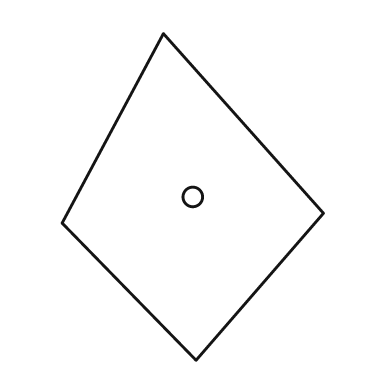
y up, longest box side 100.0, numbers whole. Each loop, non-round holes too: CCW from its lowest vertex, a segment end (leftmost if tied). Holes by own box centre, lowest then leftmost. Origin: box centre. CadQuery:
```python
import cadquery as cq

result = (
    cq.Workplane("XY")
    .moveTo(1.0, -50.0)
    .lineTo(40.0, -5.0)
    .lineTo(-9.0, 50.0)
    .lineTo(-40.0, -8.0)
    .close()
    .moveTo(0.0, 0.0)
    .circle(3.0)
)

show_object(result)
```